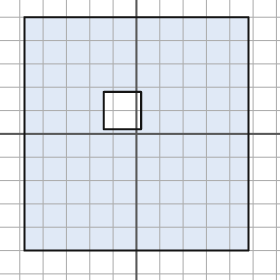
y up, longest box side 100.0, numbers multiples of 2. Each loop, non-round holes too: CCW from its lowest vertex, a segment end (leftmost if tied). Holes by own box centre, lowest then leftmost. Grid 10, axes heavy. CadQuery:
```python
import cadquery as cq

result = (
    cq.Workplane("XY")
    .moveTo(-48.0, -50.0)
    .lineTo(48.0, -50.0)
    .lineTo(48.0, 50.0)
    .lineTo(-48.0, 50.0)
    .close()
    .moveTo(-14.0, 2.0)
    .lineTo(2.0, 2.0)
    .lineTo(2.0, 18.0)
    .lineTo(-14.0, 18.0)
    .close()
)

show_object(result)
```